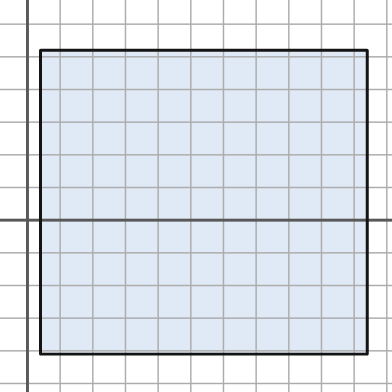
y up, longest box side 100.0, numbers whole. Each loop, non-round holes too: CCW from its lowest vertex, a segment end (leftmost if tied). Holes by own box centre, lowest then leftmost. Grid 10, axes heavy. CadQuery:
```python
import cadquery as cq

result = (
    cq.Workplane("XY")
    .moveTo(4.0, -41.0)
    .lineTo(104.0, -41.0)
    .lineTo(104.0, 52.0)
    .lineTo(4.0, 52.0)
    .close()
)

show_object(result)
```